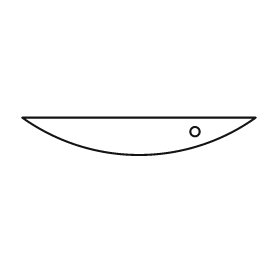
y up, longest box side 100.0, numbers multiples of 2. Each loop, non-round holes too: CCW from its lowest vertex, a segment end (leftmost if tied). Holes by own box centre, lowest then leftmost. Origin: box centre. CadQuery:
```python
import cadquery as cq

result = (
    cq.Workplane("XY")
    .moveTo(-50.0, 8.0)
    .threePointArc((0.0, -8.0), (50.0, 8.0))
    .close()
    .moveTo(24.0, 2.0)
    .circle(2.0)
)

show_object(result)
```